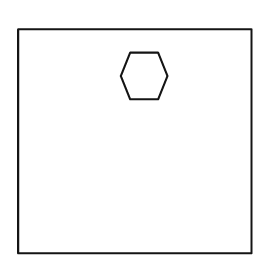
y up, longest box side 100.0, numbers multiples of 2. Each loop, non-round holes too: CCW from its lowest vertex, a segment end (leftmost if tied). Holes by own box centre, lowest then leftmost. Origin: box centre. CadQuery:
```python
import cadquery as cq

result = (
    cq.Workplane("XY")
    .moveTo(-50.0, -48.0)
    .lineTo(50.0, -48.0)
    .lineTo(50.0, 48.0)
    .lineTo(-50.0, 48.0)
    .close()
    .moveTo(-2.0, 18.0)
    .lineTo(10.0, 18.0)
    .lineTo(14.0, 28.0)
    .lineTo(10.0, 38.0)
    .lineTo(-2.0, 38.0)
    .lineTo(-6.0, 28.0)
    .close()
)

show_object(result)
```